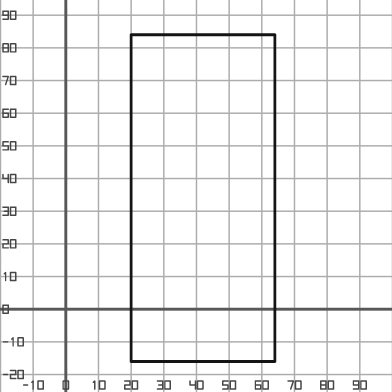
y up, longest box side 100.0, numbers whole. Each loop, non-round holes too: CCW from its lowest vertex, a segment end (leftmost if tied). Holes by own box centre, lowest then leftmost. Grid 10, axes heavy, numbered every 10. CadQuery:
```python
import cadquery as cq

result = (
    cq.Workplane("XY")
    .moveTo(20.0, -16.0)
    .lineTo(64.0, -16.0)
    .lineTo(64.0, 84.0)
    .lineTo(20.0, 84.0)
    .close()
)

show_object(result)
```